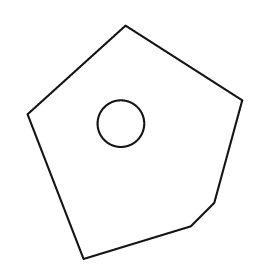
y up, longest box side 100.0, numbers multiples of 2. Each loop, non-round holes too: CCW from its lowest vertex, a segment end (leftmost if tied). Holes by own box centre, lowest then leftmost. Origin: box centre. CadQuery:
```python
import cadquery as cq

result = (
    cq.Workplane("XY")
    .moveTo(-22.0, -50.0)
    .lineTo(24.0, -36.0)
    .lineTo(34.0, -26.0)
    .lineTo(46.0, 18.0)
    .lineTo(-4.0, 50.0)
    .lineTo(-46.0, 12.0)
    .close()
    .moveTo(-6.0, 8.0)
    .circle(10.0)
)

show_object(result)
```